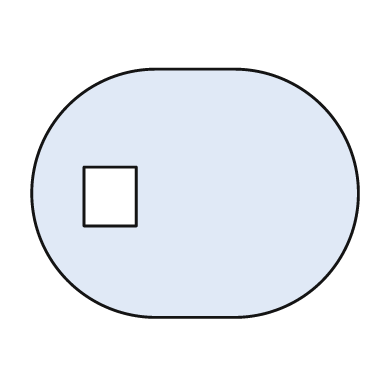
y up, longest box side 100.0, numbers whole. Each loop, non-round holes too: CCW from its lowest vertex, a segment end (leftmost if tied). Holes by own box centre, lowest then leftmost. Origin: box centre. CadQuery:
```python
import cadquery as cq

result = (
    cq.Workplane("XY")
    .moveTo(-12.0, -38.0)
    .lineTo(12.0, -38.0)
    .threePointArc((50.0, 0.0), (12.0, 38.0))
    .lineTo(-12.0, 38.0)
    .threePointArc((-50.0, 0.0), (-12.0, -38.0))
    .close()
    .moveTo(-34.0, -10.0)
    .lineTo(-18.0, -10.0)
    .lineTo(-18.0, 8.0)
    .lineTo(-34.0, 8.0)
    .close()
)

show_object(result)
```